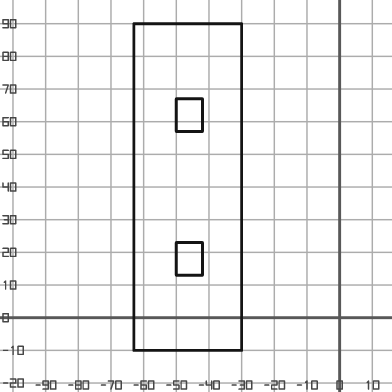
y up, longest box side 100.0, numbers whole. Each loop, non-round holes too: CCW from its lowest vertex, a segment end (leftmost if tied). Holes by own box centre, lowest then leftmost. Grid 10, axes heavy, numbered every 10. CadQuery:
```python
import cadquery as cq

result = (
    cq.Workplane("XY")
    .moveTo(-63.0, -10.0)
    .lineTo(-30.0, -10.0)
    .lineTo(-30.0, 90.0)
    .lineTo(-63.0, 90.0)
    .close()
    .moveTo(-50.0, 13.0)
    .lineTo(-42.0, 13.0)
    .lineTo(-42.0, 23.0)
    .lineTo(-50.0, 23.0)
    .close()
    .moveTo(-50.0, 57.0)
    .lineTo(-42.0, 57.0)
    .lineTo(-42.0, 67.0)
    .lineTo(-50.0, 67.0)
    .close()
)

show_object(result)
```